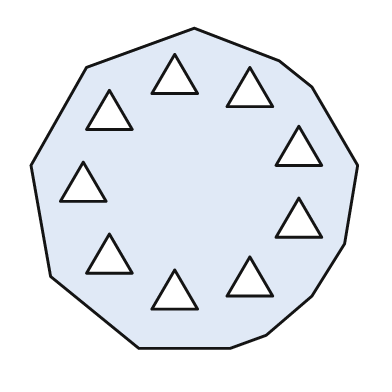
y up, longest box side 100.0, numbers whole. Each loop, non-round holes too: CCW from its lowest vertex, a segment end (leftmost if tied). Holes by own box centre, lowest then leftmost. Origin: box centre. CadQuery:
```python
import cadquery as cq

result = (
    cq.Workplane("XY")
    .moveTo(-17.0, -49.0)
    .lineTo(11.0, -49.0)
    .lineTo(22.0, -45.0)
    .lineTo(36.0, -33.0)
    .lineTo(46.0, -17.0)
    .lineTo(50.0, 7.0)
    .lineTo(36.0, 31.0)
    .lineTo(26.0, 39.0)
    .lineTo(0.0, 49.0)
    .lineTo(-33.0, 37.0)
    .lineTo(-50.0, 7.0)
    .lineTo(-44.0, -27.0)
    .close()
    .moveTo(-13.0, -37.0)
    .lineTo(1.0, -37.0)
    .lineTo(-6.0, -25.0)
    .close()
    .moveTo(10.0, -33.0)
    .lineTo(24.0, -33.0)
    .lineTo(17.0, -21.0)
    .close()
    .moveTo(-33.0, -26.0)
    .lineTo(-19.0, -26.0)
    .lineTo(-26.0, -14.0)
    .close()
    .moveTo(25.0, -15.0)
    .lineTo(39.0, -15.0)
    .lineTo(32.0, -3.0)
    .close()
    .moveTo(-41.0, -4.0)
    .lineTo(-27.0, -4.0)
    .lineTo(-34.0, 8.0)
    .close()
    .moveTo(25.0, 7.0)
    .lineTo(39.0, 7.0)
    .lineTo(32.0, 19.0)
    .close()
    .moveTo(-33.0, 18.0)
    .lineTo(-19.0, 18.0)
    .lineTo(-26.0, 30.0)
    .close()
    .moveTo(10.0, 25.0)
    .lineTo(24.0, 25.0)
    .lineTo(17.0, 37.0)
    .close()
    .moveTo(-13.0, 29.0)
    .lineTo(1.0, 29.0)
    .lineTo(-6.0, 41.0)
    .close()
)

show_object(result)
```